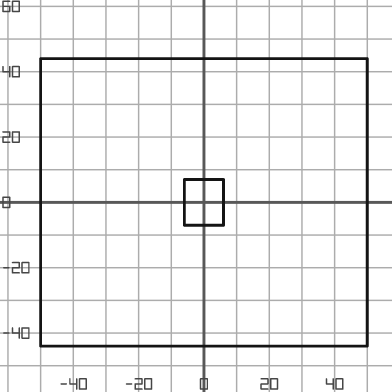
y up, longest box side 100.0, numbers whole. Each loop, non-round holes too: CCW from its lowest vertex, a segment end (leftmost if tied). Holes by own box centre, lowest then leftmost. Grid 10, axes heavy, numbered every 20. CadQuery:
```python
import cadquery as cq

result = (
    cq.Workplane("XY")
    .moveTo(-50.0, -44.0)
    .lineTo(50.0, -44.0)
    .lineTo(50.0, 44.0)
    .lineTo(-50.0, 44.0)
    .close()
    .moveTo(-6.0, -7.0)
    .lineTo(6.0, -7.0)
    .lineTo(6.0, 7.0)
    .lineTo(-6.0, 7.0)
    .close()
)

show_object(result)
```